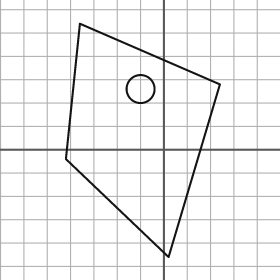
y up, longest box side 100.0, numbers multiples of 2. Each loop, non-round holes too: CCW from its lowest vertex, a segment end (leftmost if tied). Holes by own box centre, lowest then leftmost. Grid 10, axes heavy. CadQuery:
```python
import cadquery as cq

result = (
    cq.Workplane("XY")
    .moveTo(2.0, -46.0)
    .lineTo(24.0, 28.0)
    .lineTo(-36.0, 54.0)
    .lineTo(-42.0, -4.0)
    .close()
    .moveTo(-10.0, 26.0)
    .circle(6.0)
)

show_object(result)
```